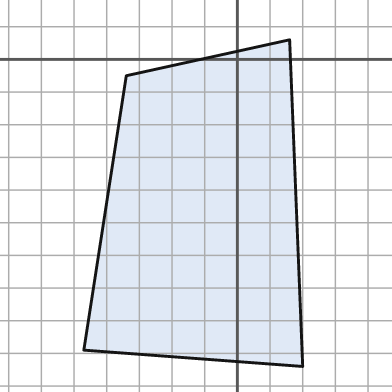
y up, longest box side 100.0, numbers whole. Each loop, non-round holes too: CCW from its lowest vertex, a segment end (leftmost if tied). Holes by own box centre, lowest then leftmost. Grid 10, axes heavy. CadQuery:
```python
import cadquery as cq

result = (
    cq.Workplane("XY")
    .moveTo(20.0, -94.0)
    .lineTo(16.0, 6.0)
    .lineTo(-34.0, -5.0)
    .lineTo(-47.0, -89.0)
    .close()
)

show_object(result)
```